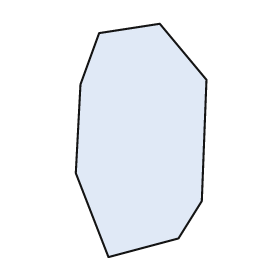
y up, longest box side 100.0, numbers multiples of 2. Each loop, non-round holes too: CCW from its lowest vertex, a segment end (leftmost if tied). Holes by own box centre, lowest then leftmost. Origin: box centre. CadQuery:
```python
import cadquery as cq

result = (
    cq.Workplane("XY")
    .moveTo(-14.0, -50.0)
    .lineTo(16.0, -42.0)
    .lineTo(26.0, -26.0)
    .lineTo(28.0, 26.0)
    .lineTo(8.0, 50.0)
    .lineTo(-18.0, 46.0)
    .lineTo(-26.0, 24.0)
    .lineTo(-28.0, -14.0)
    .close()
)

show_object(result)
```